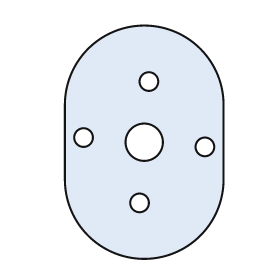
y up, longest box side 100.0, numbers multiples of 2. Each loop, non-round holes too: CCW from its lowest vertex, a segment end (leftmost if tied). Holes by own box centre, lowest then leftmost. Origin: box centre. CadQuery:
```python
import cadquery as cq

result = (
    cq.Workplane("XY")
    .moveTo(-34.0, -16.0)
    .threePointArc((0.0, -50.0), (34.0, -16.0))
    .lineTo(34.0, 16.0)
    .threePointArc((0.0, 50.0), (-34.0, 16.0))
    .close()
    .moveTo(-2.0, -26.0)
    .circle(4.0)
    .moveTo(26.0, -2.0)
    .circle(4.0)
    .moveTo(0.0, 0.0)
    .circle(8.0)
    .moveTo(-26.0, 2.0)
    .circle(4.0)
    .moveTo(2.0, 26.0)
    .circle(4.0)
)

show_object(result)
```